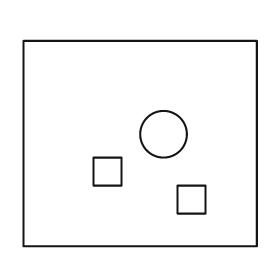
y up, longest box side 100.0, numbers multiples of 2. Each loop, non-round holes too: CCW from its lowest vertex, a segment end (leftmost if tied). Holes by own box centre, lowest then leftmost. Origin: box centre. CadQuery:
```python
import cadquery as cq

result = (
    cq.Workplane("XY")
    .moveTo(-50.0, -44.0)
    .lineTo(50.0, -44.0)
    .lineTo(50.0, 44.0)
    .lineTo(-50.0, 44.0)
    .close()
    .moveTo(16.0, -30.0)
    .lineTo(28.0, -30.0)
    .lineTo(28.0, -18.0)
    .lineTo(16.0, -18.0)
    .close()
    .moveTo(-20.0, -18.0)
    .lineTo(-8.0, -18.0)
    .lineTo(-8.0, -6.0)
    .lineTo(-20.0, -6.0)
    .close()
    .moveTo(10.0, 4.0)
    .circle(10.0)
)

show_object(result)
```